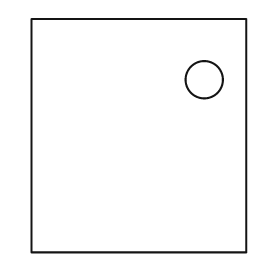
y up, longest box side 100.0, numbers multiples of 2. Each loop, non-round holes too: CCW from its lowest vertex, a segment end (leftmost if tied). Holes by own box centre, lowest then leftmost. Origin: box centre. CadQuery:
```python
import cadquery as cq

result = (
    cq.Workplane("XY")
    .moveTo(-46.0, -50.0)
    .lineTo(46.0, -50.0)
    .lineTo(46.0, 50.0)
    .lineTo(-46.0, 50.0)
    .close()
    .moveTo(28.0, 24.0)
    .circle(8.0)
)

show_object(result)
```